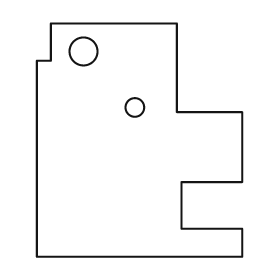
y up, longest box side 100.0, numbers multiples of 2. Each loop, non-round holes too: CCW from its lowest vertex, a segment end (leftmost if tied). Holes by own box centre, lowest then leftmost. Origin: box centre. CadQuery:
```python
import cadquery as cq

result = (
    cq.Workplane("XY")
    .moveTo(-44.0, -50.0)
    .lineTo(44.0, -50.0)
    .lineTo(44.0, -38.0)
    .lineTo(18.0, -38.0)
    .lineTo(18.0, -18.0)
    .lineTo(44.0, -18.0)
    .lineTo(44.0, 12.0)
    .lineTo(16.0, 12.0)
    .lineTo(16.0, 50.0)
    .lineTo(-38.0, 50.0)
    .lineTo(-38.0, 34.0)
    .lineTo(-44.0, 34.0)
    .close()
    .moveTo(-2.0, 14.0)
    .circle(4.0)
    .moveTo(-24.0, 38.0)
    .circle(6.0)
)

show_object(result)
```